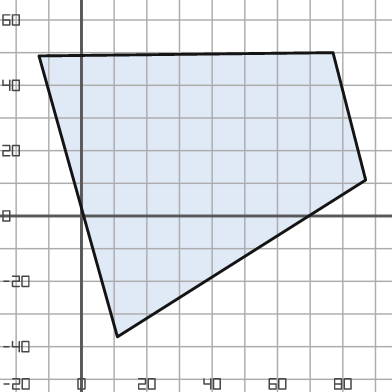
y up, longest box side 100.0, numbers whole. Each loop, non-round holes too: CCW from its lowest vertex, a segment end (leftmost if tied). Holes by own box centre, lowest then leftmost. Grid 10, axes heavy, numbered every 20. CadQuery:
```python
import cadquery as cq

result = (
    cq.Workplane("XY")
    .moveTo(11.0, -37.0)
    .lineTo(87.0, 11.0)
    .lineTo(77.0, 50.0)
    .lineTo(-13.0, 49.0)
    .close()
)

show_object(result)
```